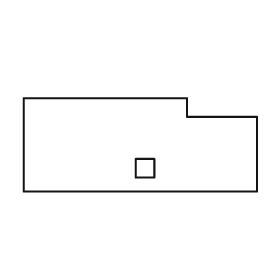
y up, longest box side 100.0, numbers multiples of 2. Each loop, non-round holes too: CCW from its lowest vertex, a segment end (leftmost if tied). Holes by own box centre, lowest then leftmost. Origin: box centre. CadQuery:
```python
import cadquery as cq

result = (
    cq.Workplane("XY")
    .moveTo(-50.0, -20.0)
    .lineTo(50.0, -20.0)
    .lineTo(50.0, 12.0)
    .lineTo(20.0, 12.0)
    .lineTo(20.0, 20.0)
    .lineTo(-50.0, 20.0)
    .close()
    .moveTo(-2.0, -14.0)
    .lineTo(6.0, -14.0)
    .lineTo(6.0, -6.0)
    .lineTo(-2.0, -6.0)
    .close()
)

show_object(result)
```